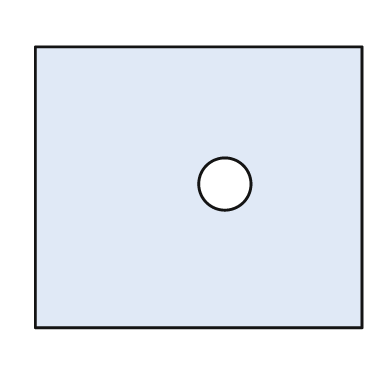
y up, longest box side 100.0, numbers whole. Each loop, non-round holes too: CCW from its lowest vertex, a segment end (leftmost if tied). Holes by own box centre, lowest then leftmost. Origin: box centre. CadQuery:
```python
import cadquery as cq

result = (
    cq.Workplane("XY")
    .moveTo(-50.0, -43.0)
    .lineTo(50.0, -43.0)
    .lineTo(50.0, 43.0)
    .lineTo(-50.0, 43.0)
    .close()
    .moveTo(8.0, 1.0)
    .circle(8.0)
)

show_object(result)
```